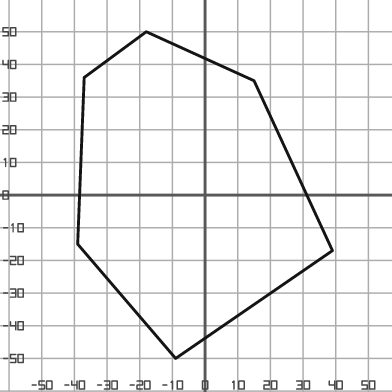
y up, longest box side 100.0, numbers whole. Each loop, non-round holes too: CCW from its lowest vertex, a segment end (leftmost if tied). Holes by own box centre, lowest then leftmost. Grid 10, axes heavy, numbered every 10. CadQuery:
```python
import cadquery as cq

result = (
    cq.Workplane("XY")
    .moveTo(-9.0, -50.0)
    .lineTo(39.0, -17.0)
    .lineTo(15.0, 35.0)
    .lineTo(-18.0, 50.0)
    .lineTo(-37.0, 36.0)
    .lineTo(-39.0, -15.0)
    .close()
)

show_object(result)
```